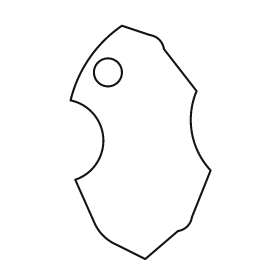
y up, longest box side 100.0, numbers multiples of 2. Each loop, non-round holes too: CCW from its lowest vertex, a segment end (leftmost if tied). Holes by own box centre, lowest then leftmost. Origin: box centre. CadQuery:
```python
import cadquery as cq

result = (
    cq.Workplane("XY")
    .moveTo(2.0, -50.0)
    .lineTo(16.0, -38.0)
    .threePointArc((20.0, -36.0), (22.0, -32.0))
    .lineTo(30.0, -12.0)
    .threePointArc((22.0, 4.0), (24.0, 22.0))
    .lineTo(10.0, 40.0)
    .threePointArc((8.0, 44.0), (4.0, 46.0))
    .lineTo(-8.0, 50.0)
    .threePointArc((-22.0, 36.0), (-30.0, 18.0))
    .threePointArc((-16.0, 2.0), (-28.0, -16.0))
    .lineTo(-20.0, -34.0)
    .threePointArc((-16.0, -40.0), (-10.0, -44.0))
    .close()
    .moveTo(-14.0, 30.0)
    .circle(6.0)
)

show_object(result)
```